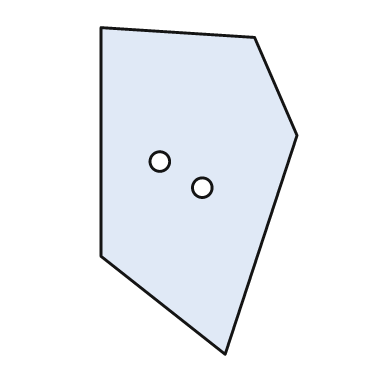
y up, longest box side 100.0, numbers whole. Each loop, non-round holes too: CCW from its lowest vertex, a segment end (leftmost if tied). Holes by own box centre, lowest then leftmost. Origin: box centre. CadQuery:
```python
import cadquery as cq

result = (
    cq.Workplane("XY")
    .moveTo(8.0, -50.0)
    .lineTo(30.0, 17.0)
    .lineTo(17.0, 47.0)
    .lineTo(-30.0, 50.0)
    .lineTo(-30.0, -20.0)
    .close()
    .moveTo(1.0, 1.0)
    .circle(3.0)
    .moveTo(-12.0, 9.0)
    .circle(3.0)
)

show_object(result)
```